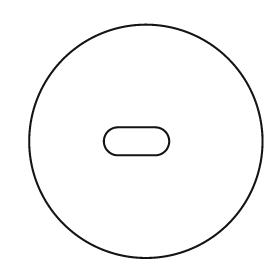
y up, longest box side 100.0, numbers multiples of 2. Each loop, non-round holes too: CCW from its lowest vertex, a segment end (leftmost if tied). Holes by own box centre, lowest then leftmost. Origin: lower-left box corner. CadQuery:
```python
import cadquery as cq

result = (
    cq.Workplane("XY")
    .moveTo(50.0, 50.0)
    .circle(50.0)
    .moveTo(38.0, 44.0)
    .lineTo(54.0, 44.0)
    .threePointArc((60.0, 50.0), (54.0, 56.0))
    .lineTo(38.0, 56.0)
    .threePointArc((32.0, 50.0), (38.0, 44.0))
    .close()
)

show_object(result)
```